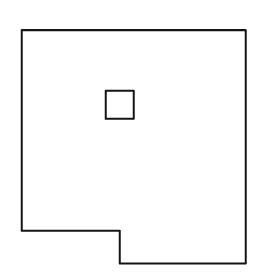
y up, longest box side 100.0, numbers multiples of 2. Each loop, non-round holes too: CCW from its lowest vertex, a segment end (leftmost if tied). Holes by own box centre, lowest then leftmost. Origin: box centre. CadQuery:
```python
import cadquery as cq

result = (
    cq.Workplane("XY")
    .moveTo(-6.0, -50.0)
    .lineTo(48.0, -50.0)
    .lineTo(48.0, 50.0)
    .lineTo(-48.0, 50.0)
    .lineTo(-48.0, -36.0)
    .lineTo(-6.0, -36.0)
    .close()
    .moveTo(-12.0, 12.0)
    .lineTo(0.0, 12.0)
    .lineTo(0.0, 24.0)
    .lineTo(-12.0, 24.0)
    .close()
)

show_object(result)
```